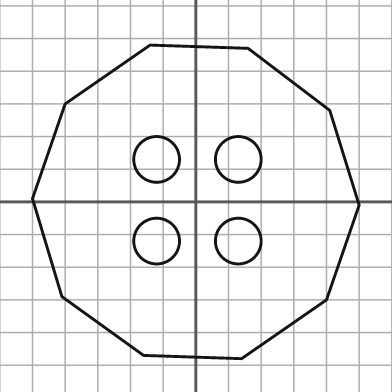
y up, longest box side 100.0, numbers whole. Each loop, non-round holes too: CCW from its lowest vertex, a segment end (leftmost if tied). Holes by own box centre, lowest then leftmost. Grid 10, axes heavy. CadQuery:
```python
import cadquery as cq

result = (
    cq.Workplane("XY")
    .moveTo(14.0, -48.0)
    .lineTo(40.0, -30.0)
    .lineTo(50.0, -1.0)
    .lineTo(41.0, 28.0)
    .lineTo(16.0, 47.0)
    .lineTo(-14.0, 48.0)
    .lineTo(-40.0, 30.0)
    .lineTo(-50.0, 1.0)
    .lineTo(-41.0, -29.0)
    .lineTo(-16.0, -47.0)
    .close()
    .moveTo(-12.0, -12.0)
    .circle(7.0)
    .moveTo(13.0, -12.0)
    .circle(7.0)
    .moveTo(-12.0, 13.0)
    .circle(7.0)
    .moveTo(13.0, 13.0)
    .circle(7.0)
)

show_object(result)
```